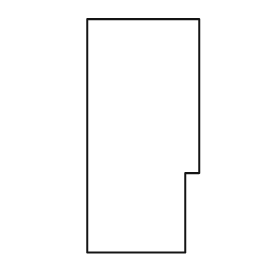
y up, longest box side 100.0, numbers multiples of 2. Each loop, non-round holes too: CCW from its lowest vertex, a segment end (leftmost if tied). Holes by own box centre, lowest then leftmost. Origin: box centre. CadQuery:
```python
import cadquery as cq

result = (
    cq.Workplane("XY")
    .moveTo(-24.0, -50.0)
    .lineTo(18.0, -50.0)
    .lineTo(18.0, -16.0)
    .lineTo(24.0, -16.0)
    .lineTo(24.0, 50.0)
    .lineTo(-24.0, 50.0)
    .close()
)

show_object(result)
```